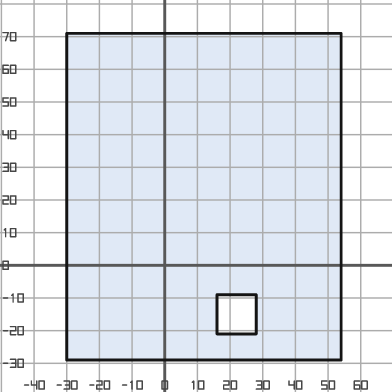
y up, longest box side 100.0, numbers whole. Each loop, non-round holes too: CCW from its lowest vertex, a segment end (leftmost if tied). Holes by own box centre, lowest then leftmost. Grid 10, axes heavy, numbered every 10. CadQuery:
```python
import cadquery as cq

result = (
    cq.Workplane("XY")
    .moveTo(-30.0, -29.0)
    .lineTo(54.0, -29.0)
    .lineTo(54.0, 71.0)
    .lineTo(-30.0, 71.0)
    .close()
    .moveTo(16.0, -21.0)
    .lineTo(28.0, -21.0)
    .lineTo(28.0, -9.0)
    .lineTo(16.0, -9.0)
    .close()
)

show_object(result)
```